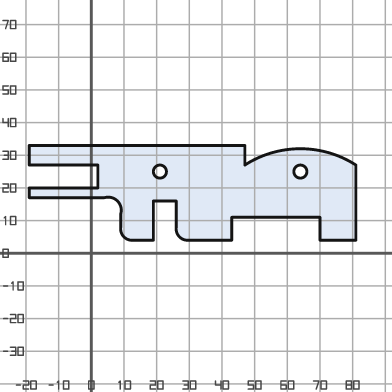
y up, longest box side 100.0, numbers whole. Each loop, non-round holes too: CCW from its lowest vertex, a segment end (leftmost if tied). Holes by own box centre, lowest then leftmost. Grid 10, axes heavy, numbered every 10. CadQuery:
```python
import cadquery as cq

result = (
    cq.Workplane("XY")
    .moveTo(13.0, 4.0)
    .lineTo(19.0, 4.0)
    .lineTo(19.0, 16.0)
    .lineTo(26.0, 16.0)
    .lineTo(26.0, 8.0)
    .threePointArc((27.0, 5.0), (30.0, 4.0))
    .lineTo(43.0, 4.0)
    .lineTo(43.0, 11.0)
    .lineTo(70.0, 11.0)
    .lineTo(70.0, 4.0)
    .lineTo(81.0, 4.0)
    .lineTo(81.0, 27.0)
    .threePointArc((64.0, 32.0), (47.0, 27.0))
    .lineTo(47.0, 33.0)
    .lineTo(-19.0, 33.0)
    .lineTo(-19.0, 27.0)
    .lineTo(2.0, 27.0)
    .lineTo(2.0, 20.0)
    .lineTo(-19.0, 20.0)
    .lineTo(-19.0, 17.0)
    .lineTo(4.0, 17.0)
    .threePointArc((8.0, 16.0), (9.0, 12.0))
    .lineTo(9.0, 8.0)
    .threePointArc((10.0, 5.0), (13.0, 4.0))
    .close()
    .moveTo(21.0, 25.0)
    .circle(2.0)
    .moveTo(64.0, 25.0)
    .circle(2.0)
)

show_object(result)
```